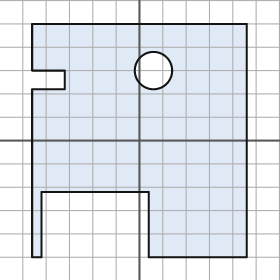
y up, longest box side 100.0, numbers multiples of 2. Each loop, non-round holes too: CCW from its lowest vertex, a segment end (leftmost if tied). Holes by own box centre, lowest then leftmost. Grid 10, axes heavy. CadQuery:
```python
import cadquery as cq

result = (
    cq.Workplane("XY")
    .moveTo(-46.0, -50.0)
    .lineTo(-42.0, -50.0)
    .lineTo(-42.0, -22.0)
    .lineTo(4.0, -22.0)
    .lineTo(4.0, -50.0)
    .lineTo(46.0, -50.0)
    .lineTo(46.0, 50.0)
    .lineTo(-46.0, 50.0)
    .lineTo(-46.0, 30.0)
    .lineTo(-32.0, 30.0)
    .lineTo(-32.0, 22.0)
    .lineTo(-46.0, 22.0)
    .close()
    .moveTo(6.0, 30.0)
    .circle(8.0)
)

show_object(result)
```